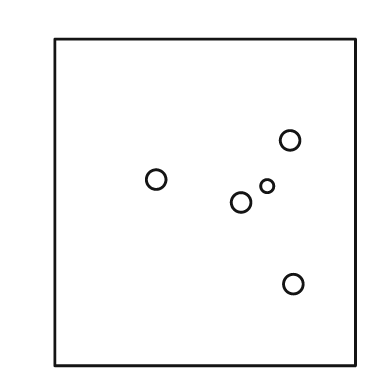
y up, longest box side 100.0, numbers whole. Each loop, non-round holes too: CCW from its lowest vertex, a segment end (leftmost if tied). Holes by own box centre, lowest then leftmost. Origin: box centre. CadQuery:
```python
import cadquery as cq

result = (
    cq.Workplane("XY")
    .moveTo(-46.0, -50.0)
    .lineTo(46.0, -50.0)
    .lineTo(46.0, 50.0)
    .lineTo(-46.0, 50.0)
    .close()
    .moveTo(27.0, -25.0)
    .circle(3.0)
    .moveTo(11.0, 0.0)
    .circle(3.0)
    .moveTo(19.0, 5.0)
    .circle(2.0)
    .moveTo(-15.0, 7.0)
    .circle(3.0)
    .moveTo(26.0, 19.0)
    .circle(3.0)
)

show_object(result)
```